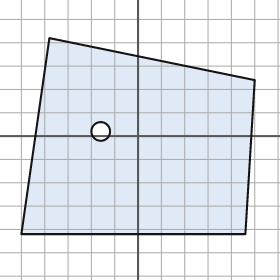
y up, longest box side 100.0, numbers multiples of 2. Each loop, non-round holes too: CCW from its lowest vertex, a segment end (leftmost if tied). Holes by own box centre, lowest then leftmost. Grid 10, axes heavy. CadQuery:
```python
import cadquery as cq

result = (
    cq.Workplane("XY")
    .moveTo(-50.0, -42.0)
    .lineTo(46.0, -42.0)
    .lineTo(50.0, 24.0)
    .lineTo(-38.0, 42.0)
    .close()
    .moveTo(-16.0, 2.0)
    .circle(4.0)
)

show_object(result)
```